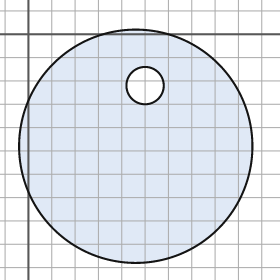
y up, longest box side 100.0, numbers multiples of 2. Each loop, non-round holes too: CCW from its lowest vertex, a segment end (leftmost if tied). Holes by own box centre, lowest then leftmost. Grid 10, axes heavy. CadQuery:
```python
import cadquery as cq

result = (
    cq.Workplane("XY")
    .moveTo(46.0, -48.0)
    .circle(50.0)
    .moveTo(50.0, -22.0)
    .circle(8.0)
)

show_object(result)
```